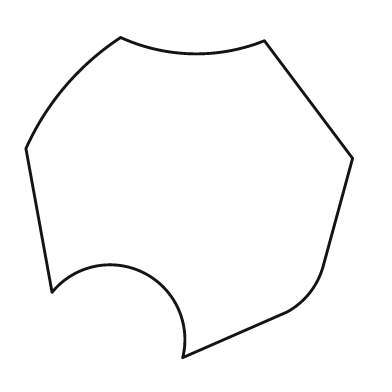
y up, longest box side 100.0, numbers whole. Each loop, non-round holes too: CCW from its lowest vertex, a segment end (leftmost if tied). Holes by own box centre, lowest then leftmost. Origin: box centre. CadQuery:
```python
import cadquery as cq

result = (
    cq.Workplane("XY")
    .moveTo(-2.0, -49.0)
    .lineTo(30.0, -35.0)
    .threePointArc((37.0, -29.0), (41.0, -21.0))
    .lineTo(50.0, 12.0)
    .lineTo(23.0, 48.0)
    .threePointArc((1.0, 44.0), (-21.0, 49.0))
    .threePointArc((-38.0, 34.0), (-50.0, 15.0))
    .lineTo(-42.0, -29.0)
    .threePointArc((-14.0, -23.0), (-2.0, -49.0))
    .close()
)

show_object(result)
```